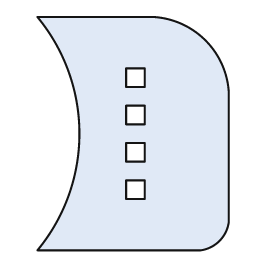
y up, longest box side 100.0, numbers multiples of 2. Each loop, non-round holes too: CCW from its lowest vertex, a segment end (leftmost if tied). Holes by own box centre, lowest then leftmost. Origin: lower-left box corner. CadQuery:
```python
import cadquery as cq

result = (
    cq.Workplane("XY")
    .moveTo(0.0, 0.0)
    .lineTo(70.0, 0.0)
    .threePointArc((78.0, 4.0), (82.0, 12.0))
    .lineTo(82.0, 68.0)
    .threePointArc((72.0, 90.0), (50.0, 100.0))
    .lineTo(0.0, 100.0)
    .threePointArc((18.0, 50.0), (0.0, 0.0))
    .close()
    .moveTo(38.0, 22.0)
    .lineTo(46.0, 22.0)
    .lineTo(46.0, 30.0)
    .lineTo(38.0, 30.0)
    .close()
    .moveTo(38.0, 38.0)
    .lineTo(46.0, 38.0)
    .lineTo(46.0, 46.0)
    .lineTo(38.0, 46.0)
    .close()
    .moveTo(38.0, 54.0)
    .lineTo(46.0, 54.0)
    .lineTo(46.0, 62.0)
    .lineTo(38.0, 62.0)
    .close()
    .moveTo(38.0, 70.0)
    .lineTo(46.0, 70.0)
    .lineTo(46.0, 78.0)
    .lineTo(38.0, 78.0)
    .close()
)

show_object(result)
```